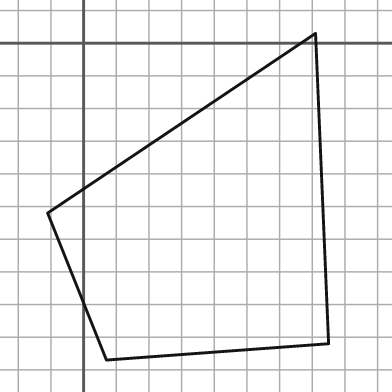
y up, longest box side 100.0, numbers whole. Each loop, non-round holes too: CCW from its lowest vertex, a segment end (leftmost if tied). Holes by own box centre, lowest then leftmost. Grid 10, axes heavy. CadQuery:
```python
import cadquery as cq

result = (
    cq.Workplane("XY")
    .moveTo(7.0, -97.0)
    .lineTo(75.0, -92.0)
    .lineTo(71.0, 3.0)
    .lineTo(-11.0, -52.0)
    .close()
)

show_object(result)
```